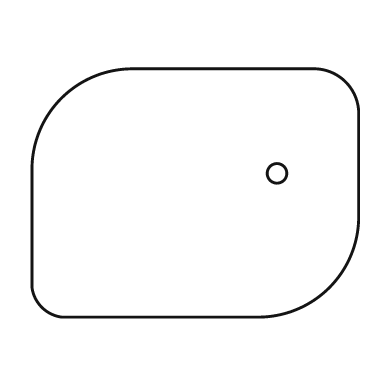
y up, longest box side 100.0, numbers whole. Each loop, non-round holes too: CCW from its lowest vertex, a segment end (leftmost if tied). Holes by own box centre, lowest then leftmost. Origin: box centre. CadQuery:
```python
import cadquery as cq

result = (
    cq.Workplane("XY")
    .moveTo(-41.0, -38.0)
    .lineTo(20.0, -38.0)
    .threePointArc((41.0, -29.0), (50.0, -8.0))
    .lineTo(50.0, 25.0)
    .threePointArc((46.0, 34.0), (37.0, 38.0))
    .lineTo(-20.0, 38.0)
    .threePointArc((-41.0, 29.0), (-50.0, 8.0))
    .lineTo(-50.0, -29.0)
    .threePointArc((-47.0, -35.0), (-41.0, -38.0))
    .close()
    .moveTo(25.0, 6.0)
    .circle(3.0)
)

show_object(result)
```